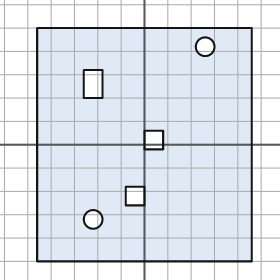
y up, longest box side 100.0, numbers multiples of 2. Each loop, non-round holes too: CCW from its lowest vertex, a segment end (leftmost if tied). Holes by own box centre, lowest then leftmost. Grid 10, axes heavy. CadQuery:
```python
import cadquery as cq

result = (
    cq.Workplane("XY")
    .moveTo(-46.0, -50.0)
    .lineTo(46.0, -50.0)
    .lineTo(46.0, 50.0)
    .lineTo(-46.0, 50.0)
    .close()
    .moveTo(-22.0, -32.0)
    .circle(4.0)
    .moveTo(-8.0, -26.0)
    .lineTo(0.0, -26.0)
    .lineTo(0.0, -18.0)
    .lineTo(-8.0, -18.0)
    .close()
    .moveTo(0.0, -2.0)
    .lineTo(8.0, -2.0)
    .lineTo(8.0, 6.0)
    .lineTo(0.0, 6.0)
    .close()
    .moveTo(-26.0, 20.0)
    .lineTo(-18.0, 20.0)
    .lineTo(-18.0, 32.0)
    .lineTo(-26.0, 32.0)
    .close()
    .moveTo(26.0, 42.0)
    .circle(4.0)
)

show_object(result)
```